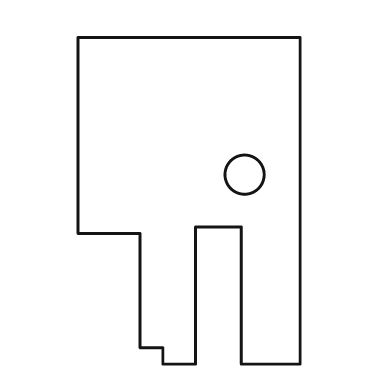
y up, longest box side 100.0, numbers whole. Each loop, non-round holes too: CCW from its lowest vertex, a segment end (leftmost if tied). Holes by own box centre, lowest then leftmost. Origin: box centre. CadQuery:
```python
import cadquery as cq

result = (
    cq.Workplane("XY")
    .moveTo(-8.0, -50.0)
    .lineTo(2.0, -50.0)
    .lineTo(2.0, -8.0)
    .lineTo(16.0, -8.0)
    .lineTo(16.0, -50.0)
    .lineTo(34.0, -50.0)
    .lineTo(34.0, 50.0)
    .lineTo(-34.0, 50.0)
    .lineTo(-34.0, -10.0)
    .lineTo(-15.0, -10.0)
    .lineTo(-15.0, -45.0)
    .lineTo(-8.0, -45.0)
    .close()
    .moveTo(17.0, 8.0)
    .circle(6.0)
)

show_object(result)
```